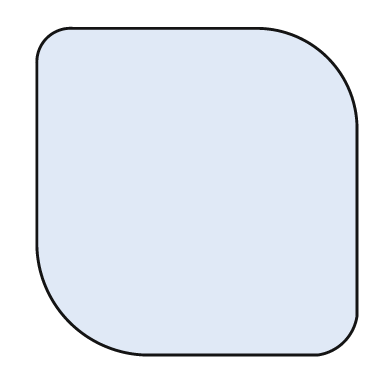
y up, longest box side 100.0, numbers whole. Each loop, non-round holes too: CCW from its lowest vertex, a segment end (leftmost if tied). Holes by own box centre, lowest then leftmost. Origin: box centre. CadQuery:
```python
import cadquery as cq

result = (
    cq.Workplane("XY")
    .moveTo(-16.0, -50.0)
    .lineTo(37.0, -50.0)
    .threePointArc((45.0, -46.0), (49.0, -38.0))
    .lineTo(49.0, 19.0)
    .threePointArc((40.0, 41.0), (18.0, 50.0))
    .lineTo(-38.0, 50.0)
    .threePointArc((-46.0, 47.0), (-49.0, 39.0))
    .lineTo(-49.0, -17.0)
    .threePointArc((-39.0, -40.0), (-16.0, -50.0))
    .close()
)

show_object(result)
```